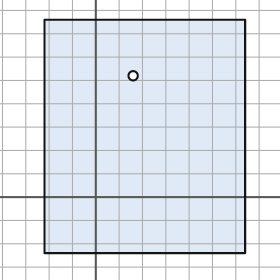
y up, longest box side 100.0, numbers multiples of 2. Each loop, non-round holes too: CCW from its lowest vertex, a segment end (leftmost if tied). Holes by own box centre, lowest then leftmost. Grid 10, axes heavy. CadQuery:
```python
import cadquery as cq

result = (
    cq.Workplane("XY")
    .moveTo(-22.0, -24.0)
    .lineTo(64.0, -24.0)
    .lineTo(64.0, 76.0)
    .lineTo(-22.0, 76.0)
    .close()
    .moveTo(16.0, 52.0)
    .circle(2.0)
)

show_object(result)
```